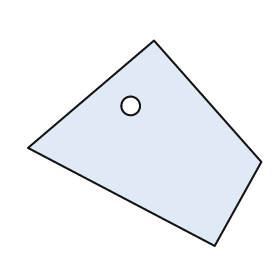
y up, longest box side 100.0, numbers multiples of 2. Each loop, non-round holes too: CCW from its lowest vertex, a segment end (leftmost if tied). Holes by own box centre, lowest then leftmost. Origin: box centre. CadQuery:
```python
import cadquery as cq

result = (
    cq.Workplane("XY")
    .moveTo(30.0, -44.0)
    .lineTo(50.0, -8.0)
    .lineTo(4.0, 44.0)
    .lineTo(-50.0, -2.0)
    .close()
    .moveTo(-6.0, 16.0)
    .circle(4.0)
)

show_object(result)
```